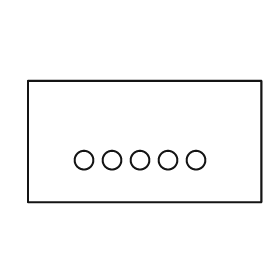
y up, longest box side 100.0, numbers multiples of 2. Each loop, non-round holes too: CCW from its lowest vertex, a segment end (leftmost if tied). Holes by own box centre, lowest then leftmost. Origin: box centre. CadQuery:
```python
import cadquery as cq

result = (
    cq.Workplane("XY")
    .moveTo(-50.0, -26.0)
    .lineTo(50.0, -26.0)
    .lineTo(50.0, 26.0)
    .lineTo(-50.0, 26.0)
    .close()
    .moveTo(-26.0, -8.0)
    .circle(4.0)
    .moveTo(-14.0, -8.0)
    .circle(4.0)
    .moveTo(-2.0, -8.0)
    .circle(4.0)
    .moveTo(10.0, -8.0)
    .circle(4.0)
    .moveTo(22.0, -8.0)
    .circle(4.0)
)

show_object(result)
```